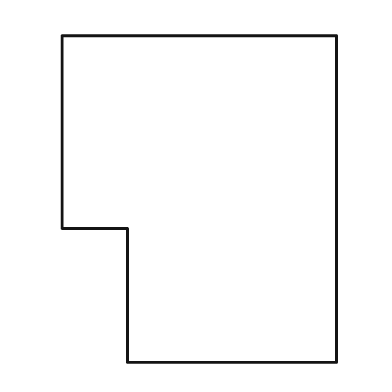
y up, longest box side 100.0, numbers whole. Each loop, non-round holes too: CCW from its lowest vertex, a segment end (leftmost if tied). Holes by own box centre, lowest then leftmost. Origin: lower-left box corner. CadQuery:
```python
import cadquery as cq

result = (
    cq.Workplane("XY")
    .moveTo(20.0, 0.0)
    .lineTo(84.0, 0.0)
    .lineTo(84.0, 100.0)
    .lineTo(0.0, 100.0)
    .lineTo(0.0, 41.0)
    .lineTo(20.0, 41.0)
    .close()
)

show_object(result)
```